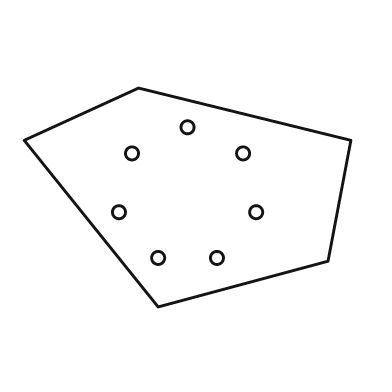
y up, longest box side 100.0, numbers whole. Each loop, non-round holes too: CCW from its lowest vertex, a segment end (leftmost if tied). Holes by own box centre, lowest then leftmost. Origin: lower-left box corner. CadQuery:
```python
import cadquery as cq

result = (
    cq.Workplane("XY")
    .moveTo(41.0, 0.0)
    .lineTo(93.0, 14.0)
    .lineTo(100.0, 51.0)
    .lineTo(35.0, 67.0)
    .lineTo(0.0, 51.0)
    .close()
    .moveTo(41.0, 15.0)
    .circle(2.0)
    .moveTo(59.0, 15.0)
    .circle(2.0)
    .moveTo(29.0, 29.0)
    .circle(2.0)
    .moveTo(71.0, 29.0)
    .circle(2.0)
    .moveTo(33.0, 47.0)
    .circle(2.0)
    .moveTo(67.0, 47.0)
    .circle(2.0)
    .moveTo(50.0, 55.0)
    .circle(2.0)
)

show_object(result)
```